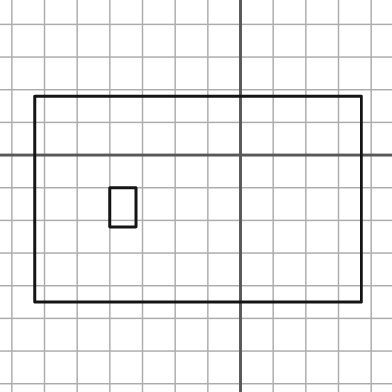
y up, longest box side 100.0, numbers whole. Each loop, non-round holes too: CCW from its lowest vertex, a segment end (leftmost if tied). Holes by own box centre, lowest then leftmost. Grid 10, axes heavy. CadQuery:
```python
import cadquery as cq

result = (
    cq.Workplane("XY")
    .moveTo(-63.0, -45.0)
    .lineTo(37.0, -45.0)
    .lineTo(37.0, 18.0)
    .lineTo(-63.0, 18.0)
    .close()
    .moveTo(-40.0, -22.0)
    .lineTo(-32.0, -22.0)
    .lineTo(-32.0, -10.0)
    .lineTo(-40.0, -10.0)
    .close()
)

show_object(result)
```